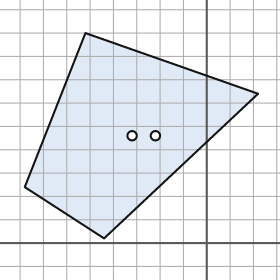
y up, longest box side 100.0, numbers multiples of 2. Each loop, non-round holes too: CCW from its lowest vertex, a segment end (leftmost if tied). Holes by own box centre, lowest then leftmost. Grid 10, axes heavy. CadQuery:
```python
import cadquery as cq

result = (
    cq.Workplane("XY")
    .moveTo(-44.0, 2.0)
    .lineTo(22.0, 64.0)
    .lineTo(-52.0, 90.0)
    .lineTo(-78.0, 24.0)
    .close()
    .moveTo(-32.0, 46.0)
    .circle(2.0)
    .moveTo(-22.0, 46.0)
    .circle(2.0)
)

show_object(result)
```